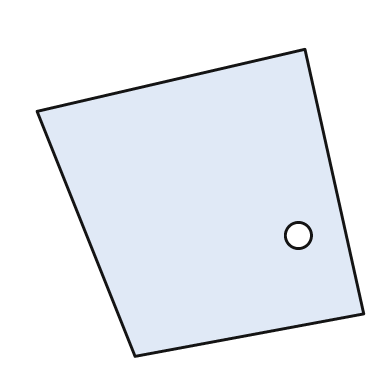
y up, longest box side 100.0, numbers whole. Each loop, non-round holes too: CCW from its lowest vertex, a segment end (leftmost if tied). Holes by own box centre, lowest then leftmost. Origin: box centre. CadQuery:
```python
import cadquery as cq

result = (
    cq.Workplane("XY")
    .moveTo(-20.0, -47.0)
    .lineTo(50.0, -34.0)
    .lineTo(32.0, 47.0)
    .lineTo(-50.0, 28.0)
    .close()
    .moveTo(30.0, -10.0)
    .circle(4.0)
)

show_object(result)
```